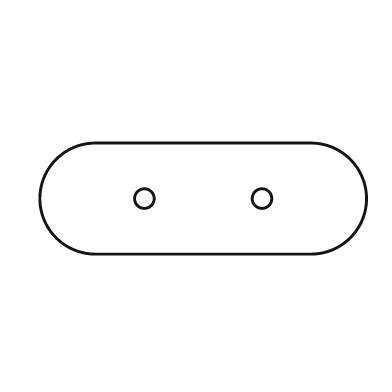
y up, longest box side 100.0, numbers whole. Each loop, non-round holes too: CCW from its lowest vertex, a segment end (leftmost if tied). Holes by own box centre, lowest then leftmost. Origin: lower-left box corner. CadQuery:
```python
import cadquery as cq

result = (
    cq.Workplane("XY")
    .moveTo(17.0, 0.0)
    .lineTo(83.0, 0.0)
    .threePointArc((100.0, 17.0), (83.0, 34.0))
    .lineTo(17.0, 34.0)
    .threePointArc((0.0, 17.0), (17.0, 0.0))
    .close()
    .moveTo(32.0, 17.0)
    .circle(3.0)
    .moveTo(68.0, 17.0)
    .circle(3.0)
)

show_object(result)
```